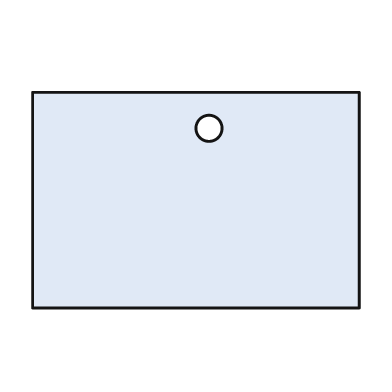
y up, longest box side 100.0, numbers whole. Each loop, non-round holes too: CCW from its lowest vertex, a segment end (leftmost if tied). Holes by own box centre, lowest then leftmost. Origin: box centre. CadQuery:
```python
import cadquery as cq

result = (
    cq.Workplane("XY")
    .moveTo(-50.0, -33.0)
    .lineTo(50.0, -33.0)
    .lineTo(50.0, 33.0)
    .lineTo(-50.0, 33.0)
    .close()
    .moveTo(4.0, 22.0)
    .circle(4.0)
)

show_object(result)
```